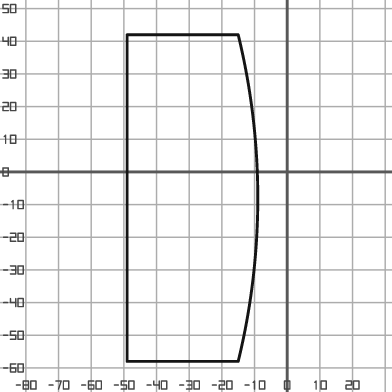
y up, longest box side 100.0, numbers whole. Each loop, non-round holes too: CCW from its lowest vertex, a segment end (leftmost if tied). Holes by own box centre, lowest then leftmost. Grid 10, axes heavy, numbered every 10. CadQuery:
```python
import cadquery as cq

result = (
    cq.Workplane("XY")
    .moveTo(-49.0, -58.0)
    .lineTo(-15.0, -58.0)
    .threePointArc((-9.0, -8.0), (-15.0, 42.0))
    .lineTo(-49.0, 42.0)
    .close()
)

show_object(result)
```